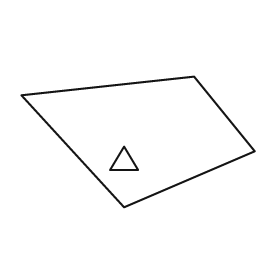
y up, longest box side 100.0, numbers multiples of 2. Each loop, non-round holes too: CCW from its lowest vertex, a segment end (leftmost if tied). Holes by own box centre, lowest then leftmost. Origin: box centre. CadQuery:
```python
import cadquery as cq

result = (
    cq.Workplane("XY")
    .moveTo(-6.0, -28.0)
    .lineTo(50.0, -4.0)
    .lineTo(24.0, 28.0)
    .lineTo(-50.0, 20.0)
    .close()
    .moveTo(-12.0, -12.0)
    .lineTo(0.0, -12.0)
    .lineTo(-6.0, -2.0)
    .close()
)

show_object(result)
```